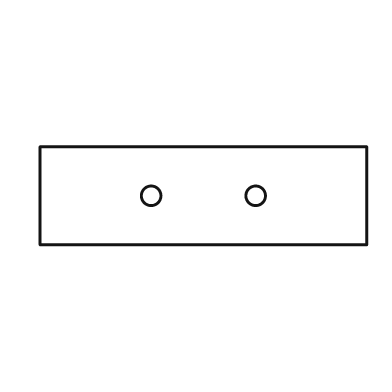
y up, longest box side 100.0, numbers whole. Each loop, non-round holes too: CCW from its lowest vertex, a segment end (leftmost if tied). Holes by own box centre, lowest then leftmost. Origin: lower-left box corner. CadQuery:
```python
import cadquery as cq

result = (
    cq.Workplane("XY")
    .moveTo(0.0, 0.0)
    .lineTo(100.0, 0.0)
    .lineTo(100.0, 30.0)
    .lineTo(0.0, 30.0)
    .close()
    .moveTo(34.0, 15.0)
    .circle(3.0)
    .moveTo(66.0, 15.0)
    .circle(3.0)
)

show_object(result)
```